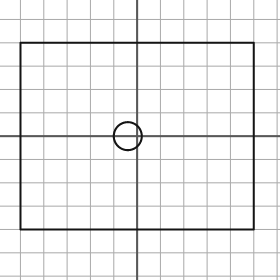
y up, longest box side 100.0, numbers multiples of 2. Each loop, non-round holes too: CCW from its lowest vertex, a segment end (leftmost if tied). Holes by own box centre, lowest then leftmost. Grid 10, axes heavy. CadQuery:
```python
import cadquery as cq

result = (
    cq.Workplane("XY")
    .moveTo(-50.0, -40.0)
    .lineTo(50.0, -40.0)
    .lineTo(50.0, 40.0)
    .lineTo(-50.0, 40.0)
    .close()
    .moveTo(-4.0, 0.0)
    .circle(6.0)
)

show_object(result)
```